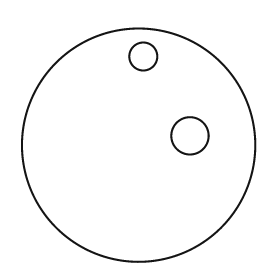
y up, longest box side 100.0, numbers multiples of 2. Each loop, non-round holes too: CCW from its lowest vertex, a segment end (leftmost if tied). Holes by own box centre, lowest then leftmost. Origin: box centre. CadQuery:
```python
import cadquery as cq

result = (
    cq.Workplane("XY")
    .moveTo(0.0, 0.0)
    .circle(50.0)
    .moveTo(22.0, 4.0)
    .circle(8.0)
    .moveTo(2.0, 38.0)
    .circle(6.0)
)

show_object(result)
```